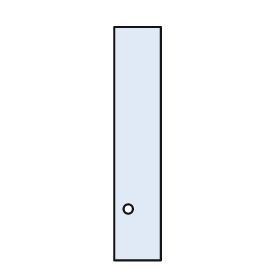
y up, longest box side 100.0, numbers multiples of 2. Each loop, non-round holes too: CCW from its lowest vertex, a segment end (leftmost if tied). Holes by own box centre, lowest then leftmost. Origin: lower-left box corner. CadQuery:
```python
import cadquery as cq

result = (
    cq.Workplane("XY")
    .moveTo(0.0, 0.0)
    .lineTo(20.0, 0.0)
    .lineTo(20.0, 100.0)
    .lineTo(0.0, 100.0)
    .close()
    .moveTo(6.0, 22.0)
    .circle(2.0)
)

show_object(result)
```